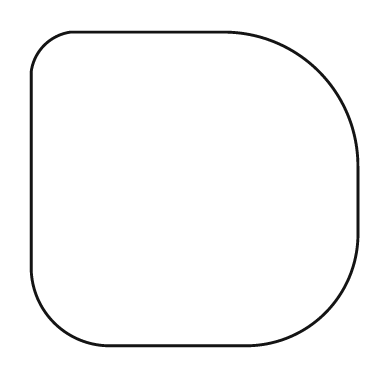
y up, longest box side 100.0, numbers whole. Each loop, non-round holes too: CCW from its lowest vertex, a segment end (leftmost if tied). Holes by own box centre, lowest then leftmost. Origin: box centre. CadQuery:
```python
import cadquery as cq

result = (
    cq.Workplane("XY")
    .moveTo(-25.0, -48.0)
    .lineTo(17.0, -48.0)
    .threePointArc((40.0, -38.0), (50.0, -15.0))
    .lineTo(50.0, 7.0)
    .threePointArc((38.0, 36.0), (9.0, 48.0))
    .lineTo(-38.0, 48.0)
    .threePointArc((-46.0, 44.0), (-50.0, 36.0))
    .lineTo(-50.0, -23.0)
    .threePointArc((-43.0, -41.0), (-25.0, -48.0))
    .close()
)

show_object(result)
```